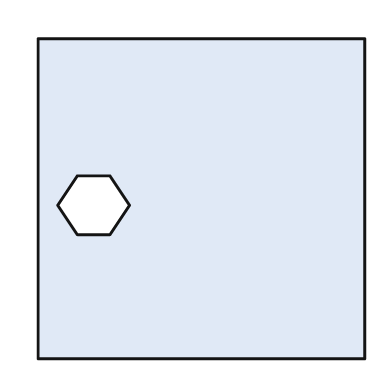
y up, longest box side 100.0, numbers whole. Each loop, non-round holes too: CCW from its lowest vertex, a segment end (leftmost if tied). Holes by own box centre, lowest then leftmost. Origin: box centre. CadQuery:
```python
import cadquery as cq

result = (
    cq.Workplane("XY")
    .moveTo(-50.0, -49.0)
    .lineTo(50.0, -49.0)
    .lineTo(50.0, 49.0)
    .lineTo(-50.0, 49.0)
    .close()
    .moveTo(-38.0, -11.0)
    .lineTo(-28.0, -11.0)
    .lineTo(-22.0, -2.0)
    .lineTo(-28.0, 7.0)
    .lineTo(-38.0, 7.0)
    .lineTo(-44.0, -2.0)
    .close()
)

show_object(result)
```